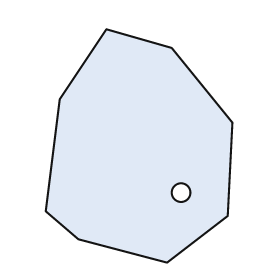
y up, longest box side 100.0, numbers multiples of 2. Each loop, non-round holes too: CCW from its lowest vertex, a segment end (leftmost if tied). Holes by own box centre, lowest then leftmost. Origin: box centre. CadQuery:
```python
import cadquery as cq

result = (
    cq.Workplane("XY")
    .moveTo(12.0, -50.0)
    .lineTo(38.0, -30.0)
    .lineTo(40.0, 10.0)
    .lineTo(14.0, 42.0)
    .lineTo(-14.0, 50.0)
    .lineTo(-34.0, 20.0)
    .lineTo(-40.0, -28.0)
    .lineTo(-26.0, -40.0)
    .close()
    .moveTo(18.0, -20.0)
    .circle(4.0)
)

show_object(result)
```